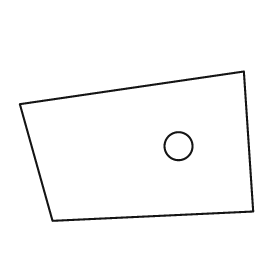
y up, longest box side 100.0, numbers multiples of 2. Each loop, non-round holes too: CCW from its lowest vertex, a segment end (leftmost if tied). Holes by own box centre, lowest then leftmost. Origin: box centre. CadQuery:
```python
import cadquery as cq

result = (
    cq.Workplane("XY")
    .moveTo(-36.0, -32.0)
    .lineTo(50.0, -28.0)
    .lineTo(46.0, 32.0)
    .lineTo(-50.0, 18.0)
    .close()
    .moveTo(18.0, 0.0)
    .circle(6.0)
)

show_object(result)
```